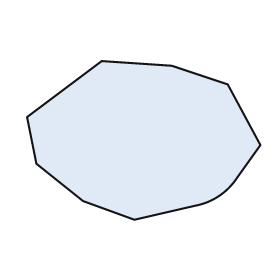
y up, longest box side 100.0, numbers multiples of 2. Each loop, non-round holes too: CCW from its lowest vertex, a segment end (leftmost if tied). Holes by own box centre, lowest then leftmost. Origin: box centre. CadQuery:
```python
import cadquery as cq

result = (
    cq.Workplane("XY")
    .moveTo(-4.0, -34.0)
    .lineTo(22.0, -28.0)
    .threePointArc((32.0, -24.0), (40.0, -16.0))
    .lineTo(50.0, -2.0)
    .lineTo(36.0, 24.0)
    .lineTo(12.0, 32.0)
    .lineTo(-18.0, 34.0)
    .lineTo(-50.0, 10.0)
    .lineTo(-46.0, -10.0)
    .lineTo(-26.0, -26.0)
    .close()
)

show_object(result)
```